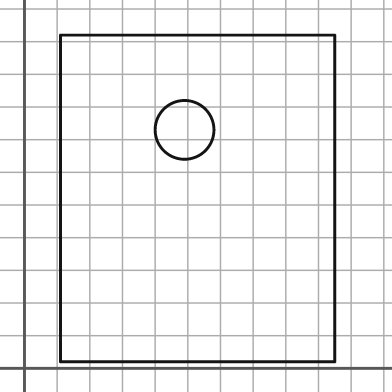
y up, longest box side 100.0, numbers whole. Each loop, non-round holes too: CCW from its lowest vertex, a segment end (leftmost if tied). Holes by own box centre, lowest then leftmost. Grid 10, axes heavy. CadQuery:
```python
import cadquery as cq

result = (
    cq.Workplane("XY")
    .moveTo(11.0, 2.0)
    .lineTo(95.0, 2.0)
    .lineTo(95.0, 102.0)
    .lineTo(11.0, 102.0)
    .close()
    .moveTo(49.0, 73.0)
    .circle(9.0)
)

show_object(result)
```